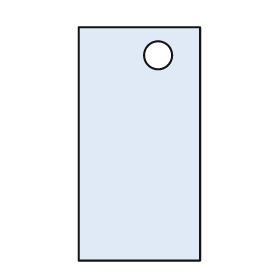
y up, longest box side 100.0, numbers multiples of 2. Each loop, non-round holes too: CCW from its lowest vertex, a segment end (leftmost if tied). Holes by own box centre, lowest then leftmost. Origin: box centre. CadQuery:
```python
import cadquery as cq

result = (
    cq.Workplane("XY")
    .moveTo(-26.0, -50.0)
    .lineTo(26.0, -50.0)
    .lineTo(26.0, 50.0)
    .lineTo(-26.0, 50.0)
    .close()
    .moveTo(8.0, 38.0)
    .circle(6.0)
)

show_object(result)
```